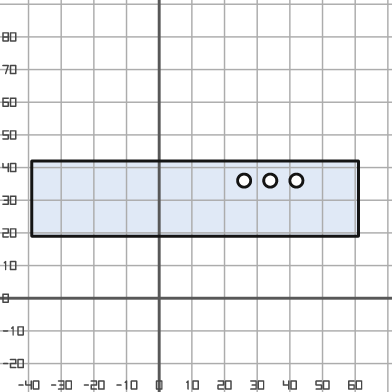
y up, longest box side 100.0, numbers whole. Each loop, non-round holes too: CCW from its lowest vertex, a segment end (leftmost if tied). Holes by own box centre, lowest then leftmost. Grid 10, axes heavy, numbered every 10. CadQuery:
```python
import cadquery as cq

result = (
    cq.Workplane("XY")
    .moveTo(-39.0, 19.0)
    .lineTo(61.0, 19.0)
    .lineTo(61.0, 42.0)
    .lineTo(-39.0, 42.0)
    .close()
    .moveTo(26.0, 36.0)
    .circle(2.0)
    .moveTo(34.0, 36.0)
    .circle(2.0)
    .moveTo(42.0, 36.0)
    .circle(2.0)
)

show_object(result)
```